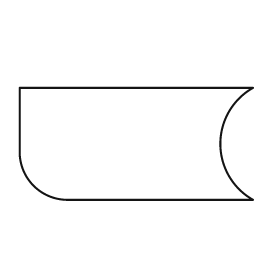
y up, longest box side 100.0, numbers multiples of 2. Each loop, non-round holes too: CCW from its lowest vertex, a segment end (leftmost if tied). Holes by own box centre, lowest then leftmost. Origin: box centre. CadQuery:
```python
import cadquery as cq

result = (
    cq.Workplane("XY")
    .moveTo(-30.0, -24.0)
    .lineTo(50.0, -24.0)
    .threePointArc((36.0, 0.0), (50.0, 24.0))
    .lineTo(-50.0, 24.0)
    .lineTo(-50.0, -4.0)
    .threePointArc((-44.0, -18.0), (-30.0, -24.0))
    .close()
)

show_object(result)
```